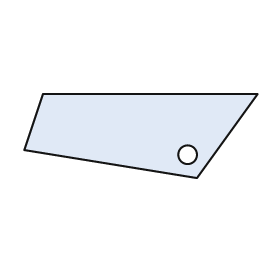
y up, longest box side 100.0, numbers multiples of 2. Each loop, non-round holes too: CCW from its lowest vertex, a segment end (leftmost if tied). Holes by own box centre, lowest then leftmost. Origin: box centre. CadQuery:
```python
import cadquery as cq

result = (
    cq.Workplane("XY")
    .moveTo(24.0, -18.0)
    .lineTo(50.0, 18.0)
    .lineTo(-42.0, 18.0)
    .lineTo(-50.0, -6.0)
    .close()
    .moveTo(20.0, -8.0)
    .circle(4.0)
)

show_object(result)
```